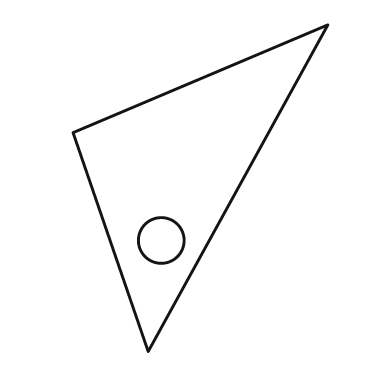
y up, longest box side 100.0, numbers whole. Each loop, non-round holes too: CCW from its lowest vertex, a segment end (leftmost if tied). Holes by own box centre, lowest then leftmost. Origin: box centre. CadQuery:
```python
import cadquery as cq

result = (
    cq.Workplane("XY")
    .moveTo(-16.0, -50.0)
    .lineTo(39.0, 50.0)
    .lineTo(-39.0, 17.0)
    .close()
    .moveTo(-12.0, -16.0)
    .circle(7.0)
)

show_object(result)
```